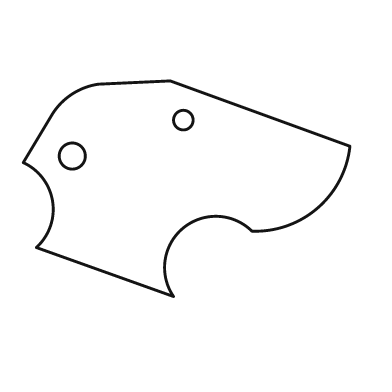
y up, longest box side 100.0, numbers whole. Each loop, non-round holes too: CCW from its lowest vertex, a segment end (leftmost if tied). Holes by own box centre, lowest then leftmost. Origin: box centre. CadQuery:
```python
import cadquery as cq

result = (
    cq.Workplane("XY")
    .moveTo(-4.0, -33.0)
    .threePointArc((-1.0, -12.0), (20.0, -13.0))
    .threePointArc((40.0, -6.0), (50.0, 13.0))
    .lineTo(-5.0, 33.0)
    .lineTo(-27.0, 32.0)
    .threePointArc((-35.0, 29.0), (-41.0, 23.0))
    .lineTo(-50.0, 8.0)
    .threePointArc((-41.0, -4.0), (-46.0, -18.0))
    .close()
    .moveTo(-35.0, 10.0)
    .circle(4.0)
    .moveTo(-1.0, 21.0)
    .circle(3.0)
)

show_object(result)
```